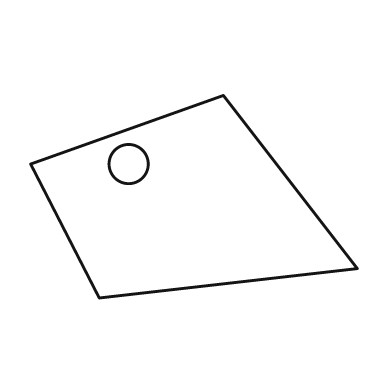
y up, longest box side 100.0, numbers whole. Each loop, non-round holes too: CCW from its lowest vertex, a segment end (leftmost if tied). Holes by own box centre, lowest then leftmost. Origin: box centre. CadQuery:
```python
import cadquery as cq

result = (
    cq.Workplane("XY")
    .moveTo(-29.0, -31.0)
    .lineTo(50.0, -22.0)
    .lineTo(9.0, 31.0)
    .lineTo(-50.0, 10.0)
    .close()
    .moveTo(-20.0, 10.0)
    .circle(6.0)
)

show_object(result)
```